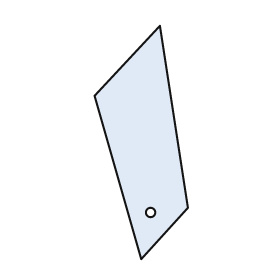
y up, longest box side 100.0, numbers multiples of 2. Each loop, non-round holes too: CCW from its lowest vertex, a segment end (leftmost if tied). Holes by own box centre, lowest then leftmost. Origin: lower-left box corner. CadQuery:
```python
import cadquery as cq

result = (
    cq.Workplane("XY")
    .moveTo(20.0, 0.0)
    .lineTo(40.0, 22.0)
    .lineTo(28.0, 100.0)
    .lineTo(0.0, 70.0)
    .close()
    .moveTo(24.0, 20.0)
    .circle(2.0)
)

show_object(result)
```